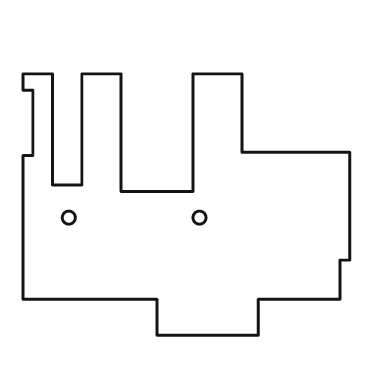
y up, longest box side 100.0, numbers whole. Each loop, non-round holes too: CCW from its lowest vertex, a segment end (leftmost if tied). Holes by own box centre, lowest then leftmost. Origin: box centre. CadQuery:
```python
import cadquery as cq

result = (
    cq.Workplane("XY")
    .moveTo(-9.0, -40.0)
    .lineTo(22.0, -40.0)
    .lineTo(22.0, -29.0)
    .lineTo(47.0, -29.0)
    .lineTo(47.0, -17.0)
    .lineTo(50.0, -17.0)
    .lineTo(50.0, 16.0)
    .lineTo(17.0, 16.0)
    .lineTo(17.0, 40.0)
    .lineTo(2.0, 40.0)
    .lineTo(2.0, 4.0)
    .lineTo(-20.0, 4.0)
    .lineTo(-20.0, 40.0)
    .lineTo(-32.0, 40.0)
    .lineTo(-32.0, 6.0)
    .lineTo(-41.0, 6.0)
    .lineTo(-41.0, 40.0)
    .lineTo(-50.0, 40.0)
    .lineTo(-50.0, 35.0)
    .lineTo(-47.0, 35.0)
    .lineTo(-47.0, 15.0)
    .lineTo(-50.0, 15.0)
    .lineTo(-50.0, -29.0)
    .lineTo(-9.0, -29.0)
    .close()
    .moveTo(-36.0, -4.0)
    .circle(2.0)
    .moveTo(4.0, -4.0)
    .circle(2.0)
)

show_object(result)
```